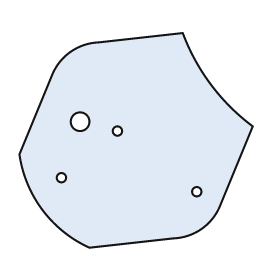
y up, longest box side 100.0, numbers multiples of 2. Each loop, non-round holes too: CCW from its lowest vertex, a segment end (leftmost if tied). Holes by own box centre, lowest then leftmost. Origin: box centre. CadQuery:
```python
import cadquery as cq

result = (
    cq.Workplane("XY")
    .moveTo(-20.0, -46.0)
    .lineTo(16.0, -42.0)
    .threePointArc((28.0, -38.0), (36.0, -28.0))
    .lineTo(50.0, 6.0)
    .threePointArc((32.0, 24.0), (20.0, 46.0))
    .lineTo(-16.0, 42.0)
    .threePointArc((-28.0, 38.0), (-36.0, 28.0))
    .lineTo(-50.0, -6.0)
    .threePointArc((-40.0, -30.0), (-20.0, -46.0))
    .close()
    .moveTo(26.0, -22.0)
    .circle(2.0)
    .moveTo(-32.0, -16.0)
    .circle(2.0)
    .moveTo(-8.0, 4.0)
    .circle(2.0)
    .moveTo(-24.0, 8.0)
    .circle(4.0)
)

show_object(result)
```